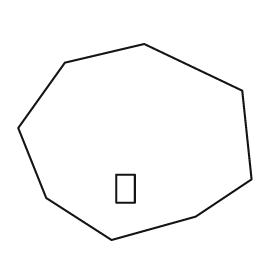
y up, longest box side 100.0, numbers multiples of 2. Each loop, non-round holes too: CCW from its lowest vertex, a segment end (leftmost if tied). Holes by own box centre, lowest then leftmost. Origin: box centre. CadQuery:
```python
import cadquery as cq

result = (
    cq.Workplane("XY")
    .moveTo(-10.0, -42.0)
    .lineTo(26.0, -32.0)
    .lineTo(50.0, -16.0)
    .lineTo(46.0, 22.0)
    .lineTo(4.0, 42.0)
    .lineTo(-30.0, 34.0)
    .lineTo(-50.0, 6.0)
    .lineTo(-38.0, -24.0)
    .close()
    .moveTo(-8.0, -26.0)
    .lineTo(0.0, -26.0)
    .lineTo(0.0, -14.0)
    .lineTo(-8.0, -14.0)
    .close()
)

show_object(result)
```